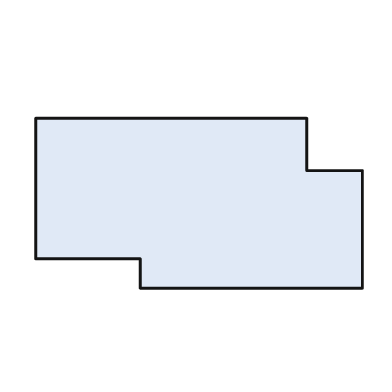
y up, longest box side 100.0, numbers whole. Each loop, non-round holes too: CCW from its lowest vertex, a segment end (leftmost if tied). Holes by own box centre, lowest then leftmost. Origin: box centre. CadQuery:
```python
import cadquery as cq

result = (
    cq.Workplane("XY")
    .moveTo(-18.0, -26.0)
    .lineTo(50.0, -26.0)
    .lineTo(50.0, 10.0)
    .lineTo(33.0, 10.0)
    .lineTo(33.0, 26.0)
    .lineTo(-50.0, 26.0)
    .lineTo(-50.0, -17.0)
    .lineTo(-18.0, -17.0)
    .close()
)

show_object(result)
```